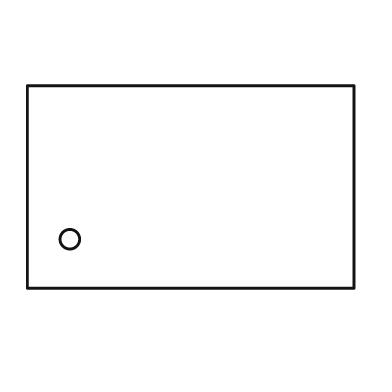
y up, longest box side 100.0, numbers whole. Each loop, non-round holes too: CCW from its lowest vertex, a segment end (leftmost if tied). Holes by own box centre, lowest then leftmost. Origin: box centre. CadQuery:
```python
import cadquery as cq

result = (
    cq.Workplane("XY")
    .moveTo(-50.0, -31.0)
    .lineTo(50.0, -31.0)
    .lineTo(50.0, 31.0)
    .lineTo(-50.0, 31.0)
    .close()
    .moveTo(-37.0, -16.0)
    .circle(3.0)
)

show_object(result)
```